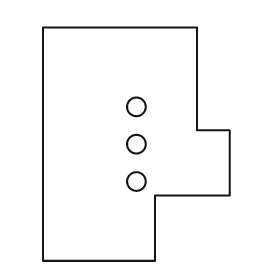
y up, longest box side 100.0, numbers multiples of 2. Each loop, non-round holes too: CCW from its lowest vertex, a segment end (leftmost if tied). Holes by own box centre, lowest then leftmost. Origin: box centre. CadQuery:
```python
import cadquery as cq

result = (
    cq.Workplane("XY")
    .moveTo(-40.0, -50.0)
    .lineTo(8.0, -50.0)
    .lineTo(8.0, -22.0)
    .lineTo(40.0, -22.0)
    .lineTo(40.0, 6.0)
    .lineTo(26.0, 6.0)
    .lineTo(26.0, 50.0)
    .lineTo(-40.0, 50.0)
    .close()
    .moveTo(0.0, -16.0)
    .circle(4.0)
    .moveTo(0.0, 0.0)
    .circle(4.0)
    .moveTo(0.0, 16.0)
    .circle(4.0)
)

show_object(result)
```